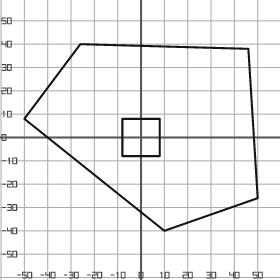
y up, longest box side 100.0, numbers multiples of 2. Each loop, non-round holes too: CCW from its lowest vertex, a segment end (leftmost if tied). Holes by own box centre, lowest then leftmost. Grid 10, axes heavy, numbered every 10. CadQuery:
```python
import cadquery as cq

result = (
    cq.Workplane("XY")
    .moveTo(10.0, -40.0)
    .lineTo(50.0, -26.0)
    .lineTo(46.0, 38.0)
    .lineTo(-26.0, 40.0)
    .lineTo(-50.0, 8.0)
    .close()
    .moveTo(-8.0, -8.0)
    .lineTo(8.0, -8.0)
    .lineTo(8.0, 8.0)
    .lineTo(-8.0, 8.0)
    .close()
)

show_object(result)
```